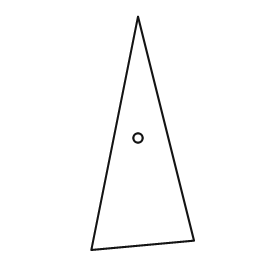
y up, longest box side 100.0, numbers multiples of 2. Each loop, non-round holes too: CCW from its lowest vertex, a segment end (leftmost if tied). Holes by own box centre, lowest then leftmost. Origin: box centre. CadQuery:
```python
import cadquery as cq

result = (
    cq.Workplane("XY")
    .moveTo(-22.0, -50.0)
    .lineTo(22.0, -46.0)
    .lineTo(-2.0, 50.0)
    .close()
    .moveTo(-2.0, -2.0)
    .circle(2.0)
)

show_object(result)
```